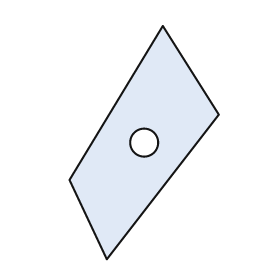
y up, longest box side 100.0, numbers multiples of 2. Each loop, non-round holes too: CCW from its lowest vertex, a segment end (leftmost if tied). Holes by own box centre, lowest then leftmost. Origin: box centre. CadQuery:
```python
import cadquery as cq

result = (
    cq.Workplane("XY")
    .moveTo(-16.0, -50.0)
    .lineTo(32.0, 12.0)
    .lineTo(8.0, 50.0)
    .lineTo(-32.0, -16.0)
    .close()
    .moveTo(0.0, 0.0)
    .circle(6.0)
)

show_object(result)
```